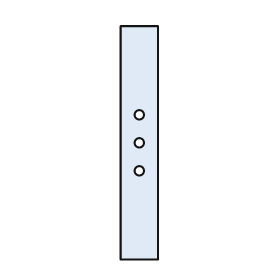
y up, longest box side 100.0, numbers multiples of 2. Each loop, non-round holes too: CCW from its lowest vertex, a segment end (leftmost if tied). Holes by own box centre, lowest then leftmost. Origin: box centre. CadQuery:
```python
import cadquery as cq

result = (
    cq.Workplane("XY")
    .moveTo(-8.0, -50.0)
    .lineTo(8.0, -50.0)
    .lineTo(8.0, 50.0)
    .lineTo(-8.0, 50.0)
    .close()
    .moveTo(0.0, -12.0)
    .circle(2.0)
    .moveTo(0.0, 0.0)
    .circle(2.0)
    .moveTo(0.0, 12.0)
    .circle(2.0)
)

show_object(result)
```